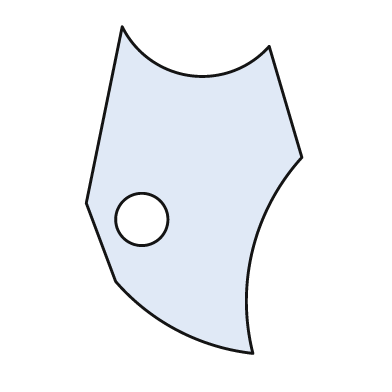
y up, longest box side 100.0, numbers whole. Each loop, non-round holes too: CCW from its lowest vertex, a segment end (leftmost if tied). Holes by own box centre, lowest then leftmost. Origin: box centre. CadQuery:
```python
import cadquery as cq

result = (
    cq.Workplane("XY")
    .moveTo(18.0, -50.0)
    .threePointArc((18.0, -18.0), (33.0, 10.0))
    .lineTo(23.0, 44.0)
    .threePointArc((-1.0, 35.0), (-22.0, 50.0))
    .lineTo(-33.0, -4.0)
    .lineTo(-24.0, -28.0)
    .threePointArc((-5.0, -43.0), (18.0, -50.0))
    .close()
    .moveTo(-16.0, -9.0)
    .circle(8.0)
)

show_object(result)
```